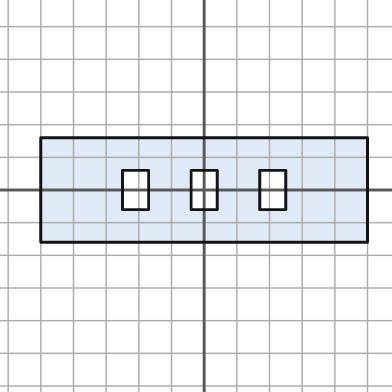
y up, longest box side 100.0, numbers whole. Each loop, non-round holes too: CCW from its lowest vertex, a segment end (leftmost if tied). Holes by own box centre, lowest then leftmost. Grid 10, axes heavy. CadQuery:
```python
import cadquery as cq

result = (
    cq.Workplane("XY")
    .moveTo(-50.0, -16.0)
    .lineTo(50.0, -16.0)
    .lineTo(50.0, 16.0)
    .lineTo(-50.0, 16.0)
    .close()
    .moveTo(-25.0, -6.0)
    .lineTo(-17.0, -6.0)
    .lineTo(-17.0, 6.0)
    .lineTo(-25.0, 6.0)
    .close()
    .moveTo(-4.0, -6.0)
    .lineTo(4.0, -6.0)
    .lineTo(4.0, 6.0)
    .lineTo(-4.0, 6.0)
    .close()
    .moveTo(17.0, -6.0)
    .lineTo(25.0, -6.0)
    .lineTo(25.0, 6.0)
    .lineTo(17.0, 6.0)
    .close()
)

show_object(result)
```